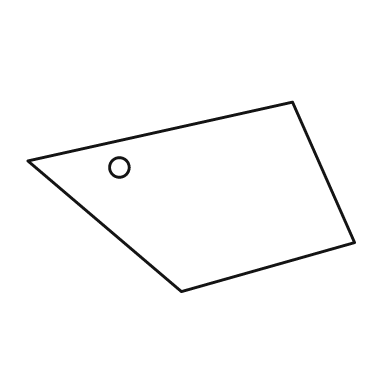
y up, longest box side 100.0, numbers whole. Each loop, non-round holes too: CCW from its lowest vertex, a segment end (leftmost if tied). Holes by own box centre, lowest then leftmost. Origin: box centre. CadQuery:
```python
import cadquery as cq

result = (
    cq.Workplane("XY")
    .moveTo(-3.0, -29.0)
    .lineTo(50.0, -14.0)
    .lineTo(31.0, 29.0)
    .lineTo(-50.0, 11.0)
    .close()
    .moveTo(-22.0, 9.0)
    .circle(3.0)
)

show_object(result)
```